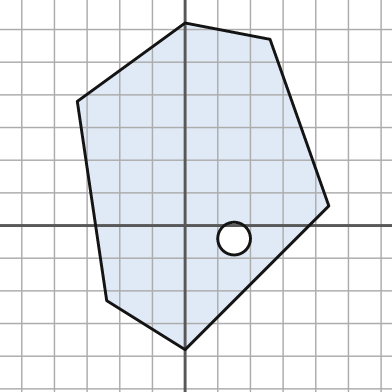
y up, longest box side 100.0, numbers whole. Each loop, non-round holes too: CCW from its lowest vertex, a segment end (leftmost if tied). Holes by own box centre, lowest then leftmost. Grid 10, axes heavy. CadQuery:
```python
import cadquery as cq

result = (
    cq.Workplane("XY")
    .moveTo(0.0, -38.0)
    .lineTo(44.0, 6.0)
    .lineTo(26.0, 57.0)
    .lineTo(0.0, 62.0)
    .lineTo(-33.0, 38.0)
    .lineTo(-24.0, -23.0)
    .close()
    .moveTo(15.0, -4.0)
    .circle(5.0)
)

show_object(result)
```